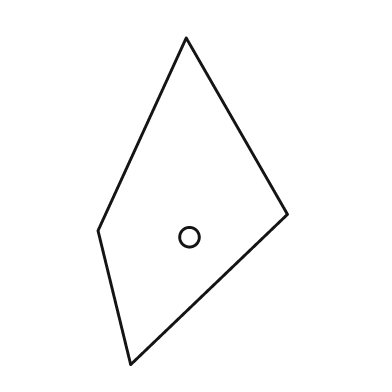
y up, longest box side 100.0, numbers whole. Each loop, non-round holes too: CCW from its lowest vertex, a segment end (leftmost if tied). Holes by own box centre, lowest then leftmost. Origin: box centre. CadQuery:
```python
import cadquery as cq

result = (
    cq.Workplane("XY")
    .moveTo(-19.0, -50.0)
    .lineTo(29.0, -4.0)
    .lineTo(-2.0, 50.0)
    .lineTo(-29.0, -9.0)
    .close()
    .moveTo(-1.0, -11.0)
    .circle(3.0)
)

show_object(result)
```